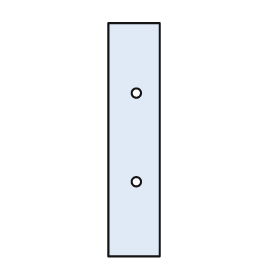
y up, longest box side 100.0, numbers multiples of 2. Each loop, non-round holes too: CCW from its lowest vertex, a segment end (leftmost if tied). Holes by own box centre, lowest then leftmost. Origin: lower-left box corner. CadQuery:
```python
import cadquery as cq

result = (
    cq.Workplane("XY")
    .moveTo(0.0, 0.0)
    .lineTo(22.0, 0.0)
    .lineTo(22.0, 100.0)
    .lineTo(0.0, 100.0)
    .close()
    .moveTo(12.0, 32.0)
    .circle(2.0)
    .moveTo(12.0, 70.0)
    .circle(2.0)
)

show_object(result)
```